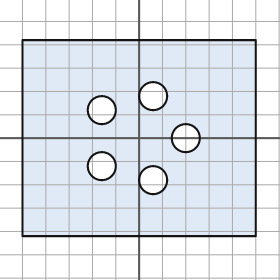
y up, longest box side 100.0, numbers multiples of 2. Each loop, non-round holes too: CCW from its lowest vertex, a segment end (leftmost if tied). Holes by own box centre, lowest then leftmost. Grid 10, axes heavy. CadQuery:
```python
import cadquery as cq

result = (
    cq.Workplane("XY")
    .moveTo(-50.0, -42.0)
    .lineTo(50.0, -42.0)
    .lineTo(50.0, 42.0)
    .lineTo(-50.0, 42.0)
    .close()
    .moveTo(6.0, -18.0)
    .circle(6.0)
    .moveTo(-16.0, -12.0)
    .circle(6.0)
    .moveTo(20.0, 0.0)
    .circle(6.0)
    .moveTo(-16.0, 12.0)
    .circle(6.0)
    .moveTo(6.0, 18.0)
    .circle(6.0)
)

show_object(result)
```